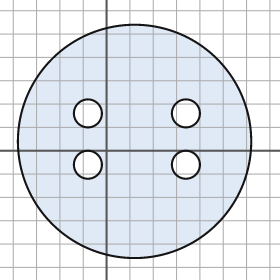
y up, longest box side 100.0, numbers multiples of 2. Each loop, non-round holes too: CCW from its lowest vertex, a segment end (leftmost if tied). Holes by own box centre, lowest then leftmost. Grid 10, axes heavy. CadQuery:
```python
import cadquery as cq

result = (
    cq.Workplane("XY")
    .moveTo(12.0, 4.0)
    .circle(50.0)
    .moveTo(-8.0, -6.0)
    .circle(6.0)
    .moveTo(34.0, -6.0)
    .circle(6.0)
    .moveTo(-8.0, 16.0)
    .circle(6.0)
    .moveTo(34.0, 16.0)
    .circle(6.0)
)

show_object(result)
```